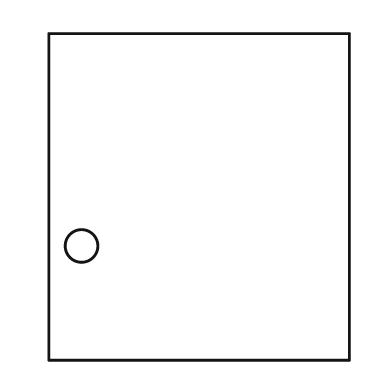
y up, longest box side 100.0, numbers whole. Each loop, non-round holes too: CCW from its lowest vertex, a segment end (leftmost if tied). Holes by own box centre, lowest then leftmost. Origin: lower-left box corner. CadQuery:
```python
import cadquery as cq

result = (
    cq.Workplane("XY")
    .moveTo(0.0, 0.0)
    .lineTo(92.0, 0.0)
    .lineTo(92.0, 100.0)
    .lineTo(0.0, 100.0)
    .close()
    .moveTo(10.0, 35.0)
    .circle(5.0)
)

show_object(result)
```